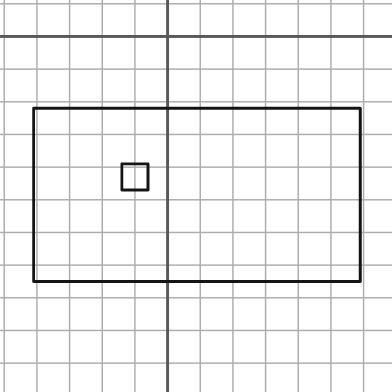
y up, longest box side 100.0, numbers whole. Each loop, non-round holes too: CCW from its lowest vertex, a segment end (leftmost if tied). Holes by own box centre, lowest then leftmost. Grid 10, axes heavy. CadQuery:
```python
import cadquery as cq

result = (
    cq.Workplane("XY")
    .moveTo(-41.0, -75.0)
    .lineTo(59.0, -75.0)
    .lineTo(59.0, -22.0)
    .lineTo(-41.0, -22.0)
    .close()
    .moveTo(-14.0, -47.0)
    .lineTo(-6.0, -47.0)
    .lineTo(-6.0, -39.0)
    .lineTo(-14.0, -39.0)
    .close()
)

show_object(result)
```